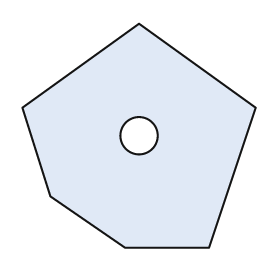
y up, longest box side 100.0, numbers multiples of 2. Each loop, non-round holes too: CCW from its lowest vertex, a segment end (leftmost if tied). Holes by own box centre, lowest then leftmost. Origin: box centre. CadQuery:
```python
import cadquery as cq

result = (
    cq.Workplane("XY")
    .moveTo(-6.0, -48.0)
    .lineTo(30.0, -48.0)
    .lineTo(50.0, 12.0)
    .lineTo(0.0, 48.0)
    .lineTo(-50.0, 12.0)
    .lineTo(-38.0, -26.0)
    .close()
    .moveTo(0.0, 0.0)
    .circle(8.0)
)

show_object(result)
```